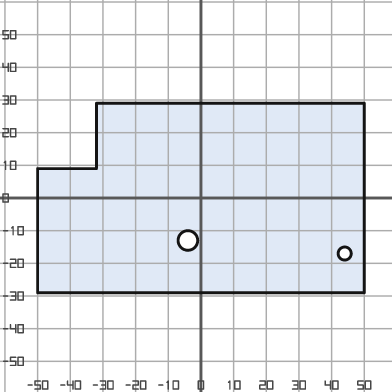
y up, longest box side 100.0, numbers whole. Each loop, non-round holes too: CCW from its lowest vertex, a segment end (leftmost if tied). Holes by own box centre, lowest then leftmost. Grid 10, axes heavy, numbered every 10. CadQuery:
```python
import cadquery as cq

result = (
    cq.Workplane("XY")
    .moveTo(-50.0, -29.0)
    .lineTo(50.0, -29.0)
    .lineTo(50.0, 29.0)
    .lineTo(-32.0, 29.0)
    .lineTo(-32.0, 9.0)
    .lineTo(-50.0, 9.0)
    .close()
    .moveTo(44.0, -17.0)
    .circle(2.0)
    .moveTo(-4.0, -13.0)
    .circle(3.0)
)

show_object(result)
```